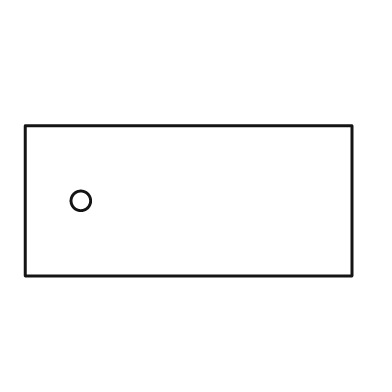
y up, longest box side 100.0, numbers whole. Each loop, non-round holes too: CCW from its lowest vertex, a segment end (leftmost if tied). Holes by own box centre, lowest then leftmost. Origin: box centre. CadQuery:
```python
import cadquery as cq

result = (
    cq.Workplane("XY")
    .moveTo(-50.0, -23.0)
    .lineTo(50.0, -23.0)
    .lineTo(50.0, 23.0)
    .lineTo(-50.0, 23.0)
    .close()
    .moveTo(-33.0, 0.0)
    .circle(3.0)
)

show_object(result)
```